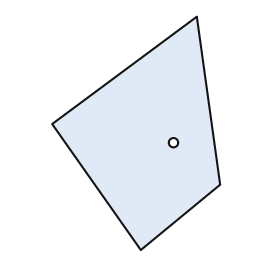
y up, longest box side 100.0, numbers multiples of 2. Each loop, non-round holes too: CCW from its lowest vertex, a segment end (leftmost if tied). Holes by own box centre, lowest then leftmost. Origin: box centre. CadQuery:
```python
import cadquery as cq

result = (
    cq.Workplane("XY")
    .moveTo(2.0, -50.0)
    .lineTo(36.0, -22.0)
    .lineTo(26.0, 50.0)
    .lineTo(-36.0, 4.0)
    .close()
    .moveTo(16.0, -4.0)
    .circle(2.0)
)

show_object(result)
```